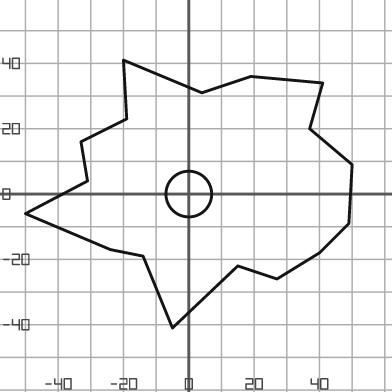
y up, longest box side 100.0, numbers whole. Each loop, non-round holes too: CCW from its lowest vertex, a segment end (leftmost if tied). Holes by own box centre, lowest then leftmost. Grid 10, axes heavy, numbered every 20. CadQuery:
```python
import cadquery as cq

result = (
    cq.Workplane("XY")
    .moveTo(-5.0, -41.0)
    .lineTo(15.0, -22.0)
    .lineTo(27.0, -26.0)
    .lineTo(40.0, -18.0)
    .lineTo(49.0, -9.0)
    .lineTo(50.0, 9.0)
    .lineTo(37.0, 20.0)
    .lineTo(41.0, 34.0)
    .lineTo(19.0, 36.0)
    .lineTo(4.0, 31.0)
    .lineTo(-20.0, 41.0)
    .lineTo(-19.0, 23.0)
    .lineTo(-33.0, 16.0)
    .lineTo(-31.0, 4.0)
    .lineTo(-50.0, -6.0)
    .lineTo(-24.0, -17.0)
    .lineTo(-14.0, -19.0)
    .close()
    .moveTo(0.0, 0.0)
    .circle(7.0)
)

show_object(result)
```